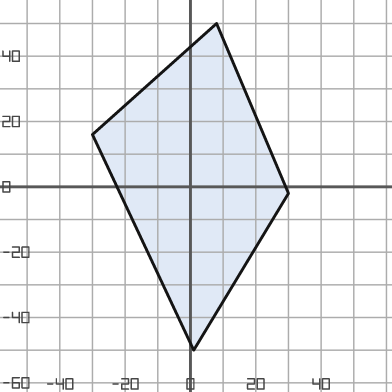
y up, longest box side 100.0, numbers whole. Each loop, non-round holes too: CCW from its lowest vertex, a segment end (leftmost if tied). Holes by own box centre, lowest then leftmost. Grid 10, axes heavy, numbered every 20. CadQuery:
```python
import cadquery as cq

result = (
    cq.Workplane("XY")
    .moveTo(1.0, -50.0)
    .lineTo(30.0, -2.0)
    .lineTo(8.0, 50.0)
    .lineTo(-30.0, 16.0)
    .close()
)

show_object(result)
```